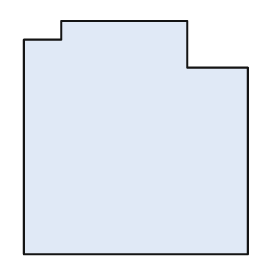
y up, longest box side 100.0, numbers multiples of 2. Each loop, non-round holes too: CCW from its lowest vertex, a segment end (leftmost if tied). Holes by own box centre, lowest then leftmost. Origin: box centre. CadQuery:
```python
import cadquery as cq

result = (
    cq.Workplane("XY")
    .moveTo(-48.0, -50.0)
    .lineTo(48.0, -50.0)
    .lineTo(48.0, 30.0)
    .lineTo(22.0, 30.0)
    .lineTo(22.0, 50.0)
    .lineTo(-32.0, 50.0)
    .lineTo(-32.0, 42.0)
    .lineTo(-48.0, 42.0)
    .close()
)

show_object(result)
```